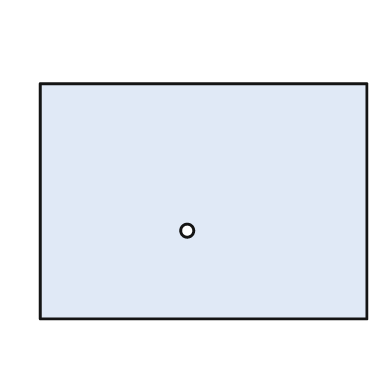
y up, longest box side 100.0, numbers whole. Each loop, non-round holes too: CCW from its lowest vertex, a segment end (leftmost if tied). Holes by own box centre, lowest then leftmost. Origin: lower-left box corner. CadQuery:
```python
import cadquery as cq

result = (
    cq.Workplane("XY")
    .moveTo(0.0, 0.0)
    .lineTo(100.0, 0.0)
    .lineTo(100.0, 72.0)
    .lineTo(0.0, 72.0)
    .close()
    .moveTo(45.0, 27.0)
    .circle(2.0)
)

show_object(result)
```